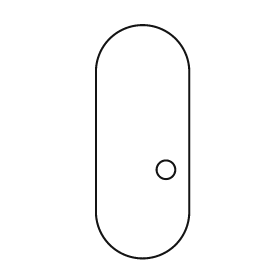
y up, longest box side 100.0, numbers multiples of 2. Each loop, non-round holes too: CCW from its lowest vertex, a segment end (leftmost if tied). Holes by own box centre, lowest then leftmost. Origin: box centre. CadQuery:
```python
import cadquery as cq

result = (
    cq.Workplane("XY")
    .moveTo(-20.0, -30.0)
    .threePointArc((0.0, -50.0), (20.0, -30.0))
    .lineTo(20.0, 30.0)
    .threePointArc((0.0, 50.0), (-20.0, 30.0))
    .close()
    .moveTo(10.0, -12.0)
    .circle(4.0)
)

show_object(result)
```